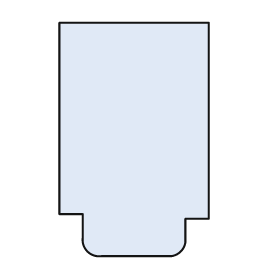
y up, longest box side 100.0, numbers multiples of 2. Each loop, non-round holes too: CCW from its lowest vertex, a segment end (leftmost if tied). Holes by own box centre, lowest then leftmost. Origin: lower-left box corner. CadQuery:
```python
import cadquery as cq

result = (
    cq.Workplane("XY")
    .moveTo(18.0, 0.0)
    .lineTo(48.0, 0.0)
    .threePointArc((52.0, 2.0), (54.0, 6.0))
    .lineTo(54.0, 16.0)
    .lineTo(64.0, 16.0)
    .lineTo(64.0, 100.0)
    .lineTo(0.0, 100.0)
    .lineTo(0.0, 18.0)
    .lineTo(10.0, 18.0)
    .lineTo(10.0, 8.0)
    .threePointArc((12.0, 2.0), (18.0, 0.0))
    .close()
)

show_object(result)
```